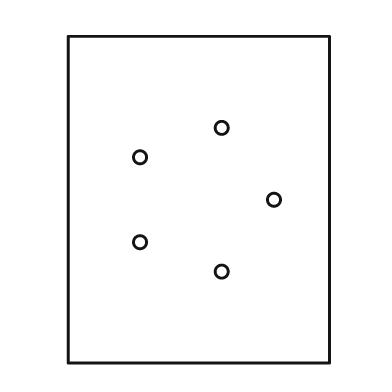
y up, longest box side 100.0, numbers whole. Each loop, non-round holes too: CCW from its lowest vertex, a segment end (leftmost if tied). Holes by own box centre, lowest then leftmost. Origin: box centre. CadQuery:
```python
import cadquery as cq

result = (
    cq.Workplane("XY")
    .moveTo(-40.0, -50.0)
    .lineTo(40.0, -50.0)
    .lineTo(40.0, 50.0)
    .lineTo(-40.0, 50.0)
    .close()
    .moveTo(7.0, -22.0)
    .circle(2.0)
    .moveTo(-18.0, -13.0)
    .circle(2.0)
    .moveTo(23.0, 0.0)
    .circle(2.0)
    .moveTo(-18.0, 13.0)
    .circle(2.0)
    .moveTo(7.0, 22.0)
    .circle(2.0)
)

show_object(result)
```